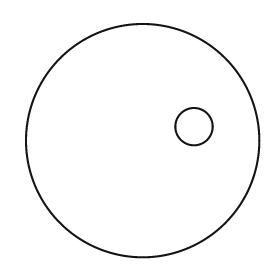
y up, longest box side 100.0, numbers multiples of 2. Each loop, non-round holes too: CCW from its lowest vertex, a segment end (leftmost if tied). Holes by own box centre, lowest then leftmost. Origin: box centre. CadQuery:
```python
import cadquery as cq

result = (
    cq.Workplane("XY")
    .moveTo(0.0, 0.0)
    .circle(50.0)
    .moveTo(22.0, 6.0)
    .circle(8.0)
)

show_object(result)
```